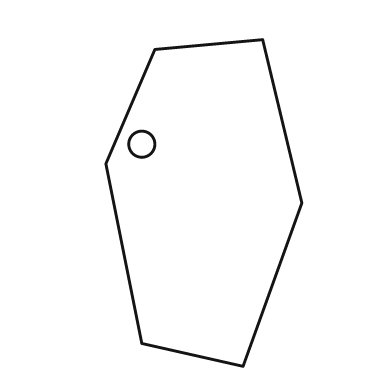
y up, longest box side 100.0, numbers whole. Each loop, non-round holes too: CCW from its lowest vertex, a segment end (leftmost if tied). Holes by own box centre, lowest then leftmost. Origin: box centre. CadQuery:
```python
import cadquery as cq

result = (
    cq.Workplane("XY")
    .moveTo(12.0, -50.0)
    .lineTo(30.0, 0.0)
    .lineTo(18.0, 50.0)
    .lineTo(-15.0, 47.0)
    .lineTo(-30.0, 12.0)
    .lineTo(-19.0, -43.0)
    .close()
    .moveTo(-19.0, 18.0)
    .circle(4.0)
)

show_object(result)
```